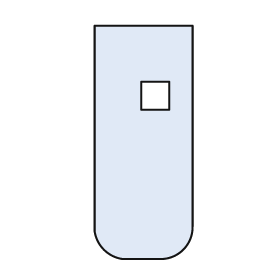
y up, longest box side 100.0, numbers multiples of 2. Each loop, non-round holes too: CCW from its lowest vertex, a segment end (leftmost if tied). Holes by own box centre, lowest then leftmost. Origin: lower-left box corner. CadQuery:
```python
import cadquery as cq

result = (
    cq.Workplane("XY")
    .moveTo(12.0, 0.0)
    .lineTo(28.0, 0.0)
    .threePointArc((38.0, 4.0), (42.0, 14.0))
    .lineTo(42.0, 100.0)
    .lineTo(0.0, 100.0)
    .lineTo(0.0, 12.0)
    .threePointArc((4.0, 4.0), (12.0, 0.0))
    .close()
    .moveTo(20.0, 64.0)
    .lineTo(32.0, 64.0)
    .lineTo(32.0, 76.0)
    .lineTo(20.0, 76.0)
    .close()
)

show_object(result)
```